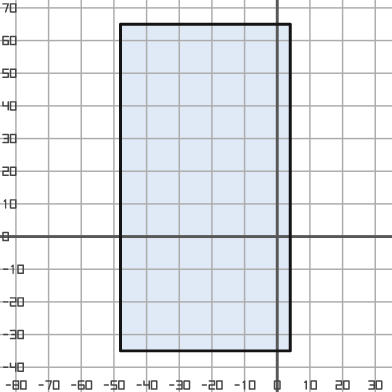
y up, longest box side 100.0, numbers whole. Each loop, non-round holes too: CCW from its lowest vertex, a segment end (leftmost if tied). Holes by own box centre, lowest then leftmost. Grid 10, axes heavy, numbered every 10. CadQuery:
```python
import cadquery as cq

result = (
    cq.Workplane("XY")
    .moveTo(-48.0, -35.0)
    .lineTo(4.0, -35.0)
    .lineTo(4.0, 65.0)
    .lineTo(-48.0, 65.0)
    .close()
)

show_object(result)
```